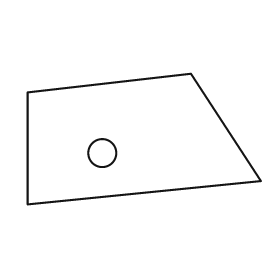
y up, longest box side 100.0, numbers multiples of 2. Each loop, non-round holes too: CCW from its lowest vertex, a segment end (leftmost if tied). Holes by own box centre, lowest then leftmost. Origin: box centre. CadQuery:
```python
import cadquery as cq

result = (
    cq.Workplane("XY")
    .moveTo(-50.0, -28.0)
    .lineTo(50.0, -18.0)
    .lineTo(20.0, 28.0)
    .lineTo(-50.0, 20.0)
    .close()
    .moveTo(-18.0, -6.0)
    .circle(6.0)
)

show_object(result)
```